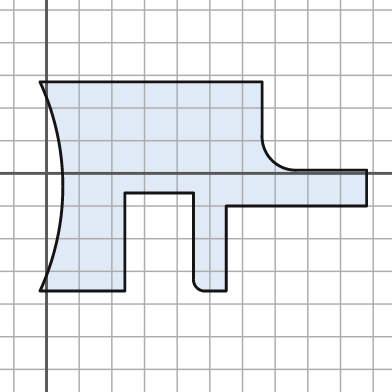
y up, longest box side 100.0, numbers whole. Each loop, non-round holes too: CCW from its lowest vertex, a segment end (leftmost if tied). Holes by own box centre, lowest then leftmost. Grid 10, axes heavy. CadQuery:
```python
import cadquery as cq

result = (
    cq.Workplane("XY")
    .moveTo(-2.0, -36.0)
    .lineTo(24.0, -36.0)
    .lineTo(24.0, -6.0)
    .lineTo(45.0, -6.0)
    .lineTo(45.0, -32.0)
    .threePointArc((46.0, -35.0), (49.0, -36.0))
    .lineTo(55.0, -36.0)
    .lineTo(55.0, -10.0)
    .lineTo(98.0, -10.0)
    .lineTo(98.0, 1.0)
    .lineTo(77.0, 1.0)
    .threePointArc((69.0, 4.0), (66.0, 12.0))
    .lineTo(66.0, 28.0)
    .lineTo(-2.0, 28.0)
    .threePointArc((5.0, -4.0), (-2.0, -36.0))
    .close()
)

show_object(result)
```